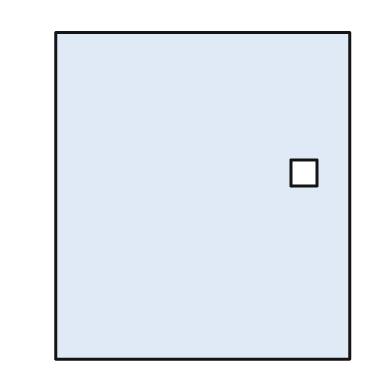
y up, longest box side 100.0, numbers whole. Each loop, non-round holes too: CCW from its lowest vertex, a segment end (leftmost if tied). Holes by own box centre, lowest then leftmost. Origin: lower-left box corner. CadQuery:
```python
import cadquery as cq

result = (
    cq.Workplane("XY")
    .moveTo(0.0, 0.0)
    .lineTo(90.0, 0.0)
    .lineTo(90.0, 100.0)
    .lineTo(0.0, 100.0)
    .close()
    .moveTo(72.0, 53.0)
    .lineTo(80.0, 53.0)
    .lineTo(80.0, 61.0)
    .lineTo(72.0, 61.0)
    .close()
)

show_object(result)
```